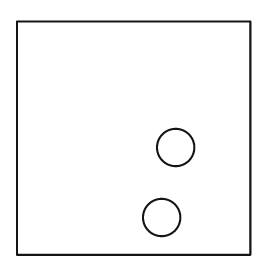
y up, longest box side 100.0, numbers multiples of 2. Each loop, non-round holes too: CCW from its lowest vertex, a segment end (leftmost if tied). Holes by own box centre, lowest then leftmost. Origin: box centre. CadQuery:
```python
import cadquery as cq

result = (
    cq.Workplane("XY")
    .moveTo(-50.0, -50.0)
    .lineTo(50.0, -50.0)
    .lineTo(50.0, 50.0)
    .lineTo(-50.0, 50.0)
    .close()
    .moveTo(12.0, -34.0)
    .circle(8.0)
    .moveTo(18.0, -4.0)
    .circle(8.0)
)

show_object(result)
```